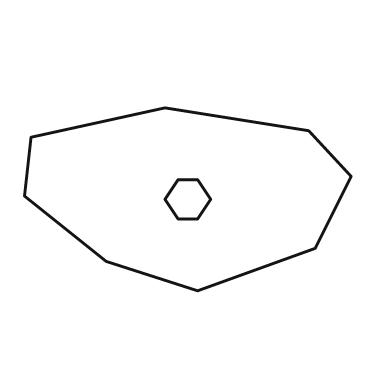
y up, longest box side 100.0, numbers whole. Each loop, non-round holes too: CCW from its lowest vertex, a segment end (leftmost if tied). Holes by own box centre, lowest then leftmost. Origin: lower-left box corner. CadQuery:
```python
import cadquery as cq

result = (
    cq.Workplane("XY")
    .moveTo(53.0, 0.0)
    .lineTo(89.0, 13.0)
    .lineTo(100.0, 35.0)
    .lineTo(87.0, 49.0)
    .lineTo(43.0, 56.0)
    .lineTo(2.0, 47.0)
    .lineTo(0.0, 29.0)
    .lineTo(25.0, 9.0)
    .close()
    .moveTo(47.0, 22.0)
    .lineTo(53.0, 22.0)
    .lineTo(57.0, 28.0)
    .lineTo(53.0, 34.0)
    .lineTo(47.0, 34.0)
    .lineTo(43.0, 28.0)
    .close()
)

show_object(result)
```